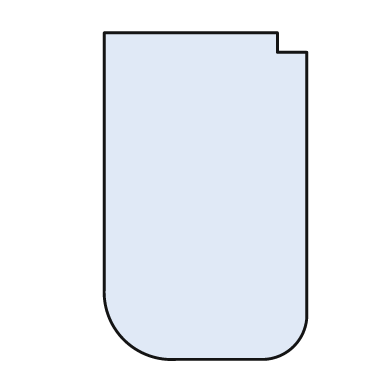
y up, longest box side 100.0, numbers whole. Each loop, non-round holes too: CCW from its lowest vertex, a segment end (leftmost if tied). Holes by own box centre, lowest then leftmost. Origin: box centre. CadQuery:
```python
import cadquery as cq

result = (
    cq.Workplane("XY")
    .moveTo(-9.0, -50.0)
    .lineTo(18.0, -50.0)
    .threePointArc((27.0, -46.0), (31.0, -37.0))
    .lineTo(31.0, 44.0)
    .lineTo(22.0, 44.0)
    .lineTo(22.0, 50.0)
    .lineTo(-31.0, 50.0)
    .lineTo(-31.0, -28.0)
    .threePointArc((-25.0, -44.0), (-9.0, -50.0))
    .close()
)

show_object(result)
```